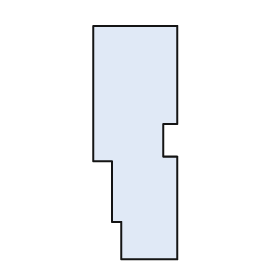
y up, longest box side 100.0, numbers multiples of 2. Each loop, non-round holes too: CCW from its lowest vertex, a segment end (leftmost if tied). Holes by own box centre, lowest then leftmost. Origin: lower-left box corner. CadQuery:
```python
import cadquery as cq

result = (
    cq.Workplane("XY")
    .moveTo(12.0, 0.0)
    .lineTo(36.0, 0.0)
    .lineTo(36.0, 44.0)
    .lineTo(30.0, 44.0)
    .lineTo(30.0, 58.0)
    .lineTo(36.0, 58.0)
    .lineTo(36.0, 100.0)
    .lineTo(0.0, 100.0)
    .lineTo(0.0, 42.0)
    .lineTo(8.0, 42.0)
    .lineTo(8.0, 16.0)
    .lineTo(12.0, 16.0)
    .close()
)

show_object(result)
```